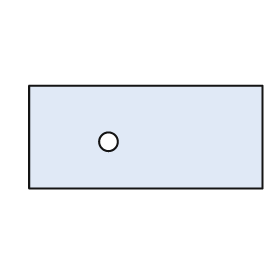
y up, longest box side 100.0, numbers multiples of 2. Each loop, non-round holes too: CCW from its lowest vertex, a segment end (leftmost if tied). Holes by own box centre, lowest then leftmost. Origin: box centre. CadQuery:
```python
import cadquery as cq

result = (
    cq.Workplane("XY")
    .moveTo(-50.0, -22.0)
    .lineTo(50.0, -22.0)
    .lineTo(50.0, 22.0)
    .lineTo(-50.0, 22.0)
    .close()
    .moveTo(-16.0, -2.0)
    .circle(4.0)
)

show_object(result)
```